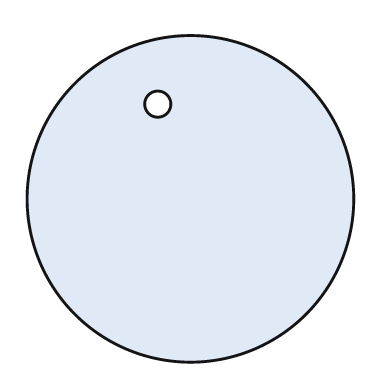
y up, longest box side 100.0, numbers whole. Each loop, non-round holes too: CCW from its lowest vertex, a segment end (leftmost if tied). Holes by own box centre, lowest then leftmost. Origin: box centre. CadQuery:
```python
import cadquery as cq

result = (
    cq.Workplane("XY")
    .moveTo(0.0, 0.0)
    .circle(50.0)
    .moveTo(-10.0, 29.0)
    .circle(4.0)
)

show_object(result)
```